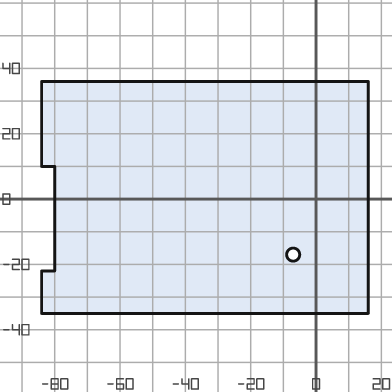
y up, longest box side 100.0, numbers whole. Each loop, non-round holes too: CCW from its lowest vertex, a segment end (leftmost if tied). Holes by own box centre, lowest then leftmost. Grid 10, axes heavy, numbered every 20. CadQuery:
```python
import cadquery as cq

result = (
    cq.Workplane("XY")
    .moveTo(-84.0, -35.0)
    .lineTo(16.0, -35.0)
    .lineTo(16.0, 36.0)
    .lineTo(-84.0, 36.0)
    .lineTo(-84.0, 10.0)
    .lineTo(-80.0, 10.0)
    .lineTo(-80.0, -22.0)
    .lineTo(-84.0, -22.0)
    .close()
    .moveTo(-7.0, -17.0)
    .circle(2.0)
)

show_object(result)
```